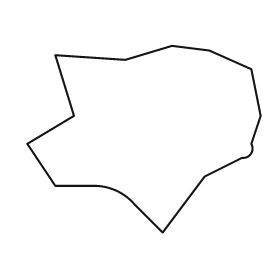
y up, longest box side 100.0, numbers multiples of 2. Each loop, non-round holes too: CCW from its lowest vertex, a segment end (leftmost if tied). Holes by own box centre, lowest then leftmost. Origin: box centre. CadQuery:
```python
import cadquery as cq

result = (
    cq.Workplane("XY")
    .moveTo(8.0, -40.0)
    .lineTo(26.0, -16.0)
    .lineTo(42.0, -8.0)
    .threePointArc((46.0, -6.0), (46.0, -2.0))
    .lineTo(50.0, 10.0)
    .lineTo(46.0, 30.0)
    .lineTo(28.0, 38.0)
    .lineTo(12.0, 40.0)
    .lineTo(-8.0, 34.0)
    .lineTo(-38.0, 36.0)
    .lineTo(-30.0, 10.0)
    .lineTo(-50.0, -2.0)
    .lineTo(-38.0, -20.0)
    .lineTo(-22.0, -20.0)
    .threePointArc((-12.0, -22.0), (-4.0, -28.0))
    .close()
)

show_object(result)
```